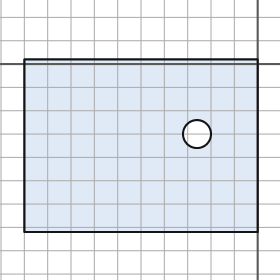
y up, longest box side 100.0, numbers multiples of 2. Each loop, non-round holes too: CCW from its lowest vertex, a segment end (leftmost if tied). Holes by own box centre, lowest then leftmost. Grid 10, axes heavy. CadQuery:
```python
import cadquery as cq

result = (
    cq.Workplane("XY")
    .moveTo(-100.0, -72.0)
    .lineTo(0.0, -72.0)
    .lineTo(0.0, 2.0)
    .lineTo(-100.0, 2.0)
    .close()
    .moveTo(-26.0, -30.0)
    .circle(6.0)
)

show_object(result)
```